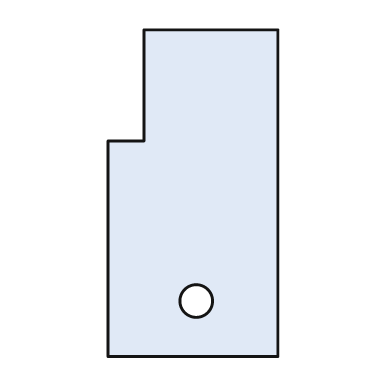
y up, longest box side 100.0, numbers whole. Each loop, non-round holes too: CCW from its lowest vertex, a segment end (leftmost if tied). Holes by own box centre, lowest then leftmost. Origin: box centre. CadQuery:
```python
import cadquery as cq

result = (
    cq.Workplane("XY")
    .moveTo(-26.0, -50.0)
    .lineTo(26.0, -50.0)
    .lineTo(26.0, 50.0)
    .lineTo(-15.0, 50.0)
    .lineTo(-15.0, 16.0)
    .lineTo(-26.0, 16.0)
    .close()
    .moveTo(1.0, -33.0)
    .circle(5.0)
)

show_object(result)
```